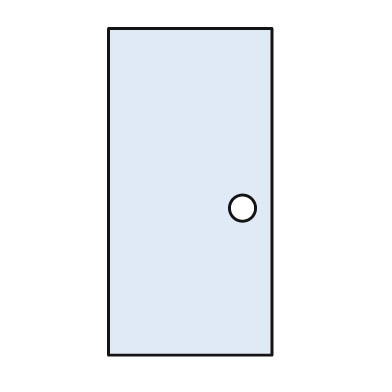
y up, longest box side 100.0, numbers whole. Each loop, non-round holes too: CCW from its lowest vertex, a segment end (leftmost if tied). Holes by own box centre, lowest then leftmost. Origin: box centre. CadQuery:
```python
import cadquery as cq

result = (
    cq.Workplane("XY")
    .moveTo(-25.0, -50.0)
    .lineTo(25.0, -50.0)
    .lineTo(25.0, 50.0)
    .lineTo(-25.0, 50.0)
    .close()
    .moveTo(16.0, -5.0)
    .circle(4.0)
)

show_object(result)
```